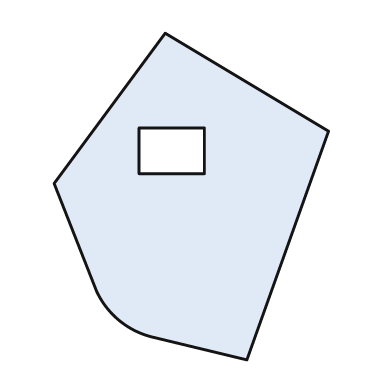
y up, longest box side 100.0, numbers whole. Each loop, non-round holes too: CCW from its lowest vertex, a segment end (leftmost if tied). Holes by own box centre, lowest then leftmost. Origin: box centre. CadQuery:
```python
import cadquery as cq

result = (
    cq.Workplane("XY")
    .moveTo(17.0, -50.0)
    .lineTo(42.0, 20.0)
    .lineTo(-8.0, 50.0)
    .lineTo(-42.0, 4.0)
    .lineTo(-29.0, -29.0)
    .threePointArc((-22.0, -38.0), (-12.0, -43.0))
    .close()
    .moveTo(-16.0, 7.0)
    .lineTo(4.0, 7.0)
    .lineTo(4.0, 21.0)
    .lineTo(-16.0, 21.0)
    .close()
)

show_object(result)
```